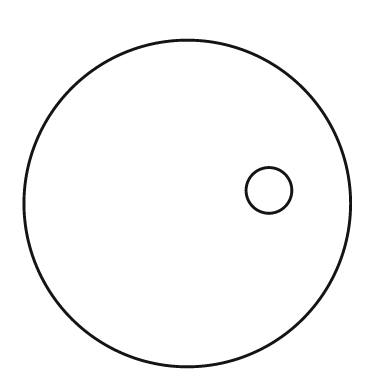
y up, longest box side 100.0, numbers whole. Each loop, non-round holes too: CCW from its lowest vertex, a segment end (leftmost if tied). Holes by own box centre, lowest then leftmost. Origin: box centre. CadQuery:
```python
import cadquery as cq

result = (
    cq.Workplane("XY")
    .moveTo(0.0, 0.0)
    .circle(50.0)
    .moveTo(25.0, 4.0)
    .circle(7.0)
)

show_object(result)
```